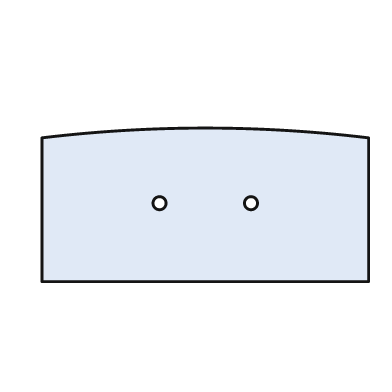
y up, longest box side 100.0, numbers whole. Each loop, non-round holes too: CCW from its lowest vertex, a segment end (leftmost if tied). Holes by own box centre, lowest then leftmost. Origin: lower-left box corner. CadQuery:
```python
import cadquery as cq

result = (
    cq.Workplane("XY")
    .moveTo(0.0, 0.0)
    .lineTo(100.0, 0.0)
    .lineTo(100.0, 44.0)
    .threePointArc((50.0, 47.0), (0.0, 44.0))
    .close()
    .moveTo(36.0, 24.0)
    .circle(2.0)
    .moveTo(64.0, 24.0)
    .circle(2.0)
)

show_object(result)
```